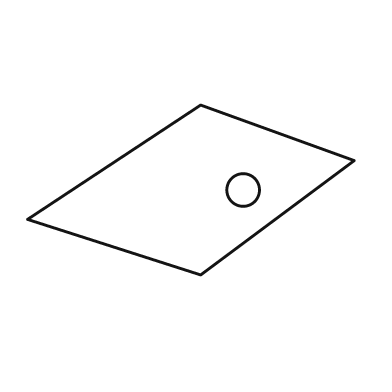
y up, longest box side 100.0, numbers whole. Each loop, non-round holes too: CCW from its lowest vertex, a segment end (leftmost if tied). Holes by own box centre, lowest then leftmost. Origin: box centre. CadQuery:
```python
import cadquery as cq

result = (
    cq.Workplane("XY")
    .moveTo(3.0, -26.0)
    .lineTo(50.0, 9.0)
    .lineTo(3.0, 26.0)
    .lineTo(-50.0, -9.0)
    .close()
    .moveTo(16.0, 0.0)
    .circle(5.0)
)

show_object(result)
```